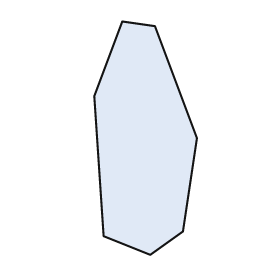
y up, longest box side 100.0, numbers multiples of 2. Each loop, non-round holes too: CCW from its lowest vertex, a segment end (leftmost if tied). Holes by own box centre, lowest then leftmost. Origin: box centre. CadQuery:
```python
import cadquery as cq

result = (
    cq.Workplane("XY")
    .moveTo(2.0, -50.0)
    .lineTo(16.0, -40.0)
    .lineTo(22.0, 0.0)
    .lineTo(4.0, 48.0)
    .lineTo(-10.0, 50.0)
    .lineTo(-22.0, 18.0)
    .lineTo(-18.0, -42.0)
    .close()
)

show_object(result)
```